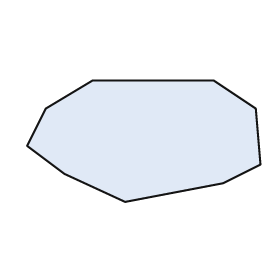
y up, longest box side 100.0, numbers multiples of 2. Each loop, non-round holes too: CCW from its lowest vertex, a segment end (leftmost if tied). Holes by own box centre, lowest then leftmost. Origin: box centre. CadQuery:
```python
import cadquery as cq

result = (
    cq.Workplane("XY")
    .moveTo(-8.0, -26.0)
    .lineTo(34.0, -18.0)
    .lineTo(50.0, -10.0)
    .lineTo(48.0, 14.0)
    .lineTo(30.0, 26.0)
    .lineTo(-22.0, 26.0)
    .lineTo(-42.0, 14.0)
    .lineTo(-50.0, -2.0)
    .lineTo(-34.0, -14.0)
    .close()
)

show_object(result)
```